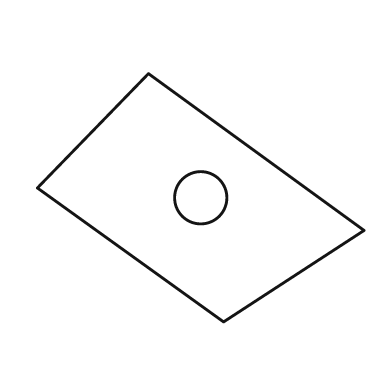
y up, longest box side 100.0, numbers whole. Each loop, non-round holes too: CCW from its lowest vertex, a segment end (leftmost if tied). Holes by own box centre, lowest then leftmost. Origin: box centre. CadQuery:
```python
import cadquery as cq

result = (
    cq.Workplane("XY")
    .moveTo(7.0, -38.0)
    .lineTo(50.0, -10.0)
    .lineTo(-16.0, 38.0)
    .lineTo(-50.0, 3.0)
    .close()
    .moveTo(0.0, 0.0)
    .circle(8.0)
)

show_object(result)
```